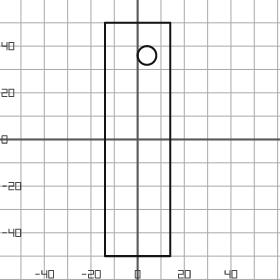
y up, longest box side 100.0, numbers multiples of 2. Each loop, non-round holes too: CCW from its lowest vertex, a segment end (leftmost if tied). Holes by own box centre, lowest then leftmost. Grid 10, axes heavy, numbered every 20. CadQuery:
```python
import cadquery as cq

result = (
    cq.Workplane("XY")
    .moveTo(-14.0, -50.0)
    .lineTo(14.0, -50.0)
    .lineTo(14.0, 50.0)
    .lineTo(-14.0, 50.0)
    .close()
    .moveTo(4.0, 36.0)
    .circle(4.0)
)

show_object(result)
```